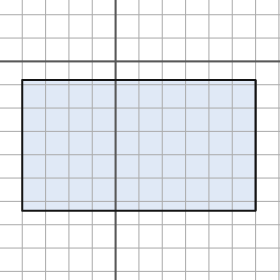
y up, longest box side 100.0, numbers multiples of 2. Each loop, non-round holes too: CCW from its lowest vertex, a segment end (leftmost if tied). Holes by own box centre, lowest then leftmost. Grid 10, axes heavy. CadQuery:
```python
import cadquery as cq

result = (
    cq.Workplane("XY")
    .moveTo(-40.0, -64.0)
    .lineTo(60.0, -64.0)
    .lineTo(60.0, -8.0)
    .lineTo(-40.0, -8.0)
    .close()
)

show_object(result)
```